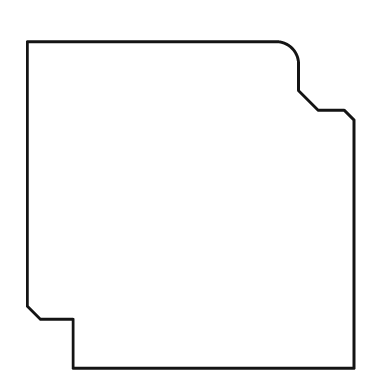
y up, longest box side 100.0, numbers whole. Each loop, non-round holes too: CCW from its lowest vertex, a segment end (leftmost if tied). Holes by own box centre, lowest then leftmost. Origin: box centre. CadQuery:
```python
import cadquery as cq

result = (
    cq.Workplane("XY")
    .moveTo(-36.0, -50.0)
    .lineTo(50.0, -50.0)
    .lineTo(50.0, 26.0)
    .lineTo(47.0, 29.0)
    .lineTo(39.0, 29.0)
    .lineTo(33.0, 35.0)
    .lineTo(33.0, 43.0)
    .threePointArc((31.0, 48.0), (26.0, 50.0))
    .lineTo(-50.0, 50.0)
    .lineTo(-50.0, -31.0)
    .lineTo(-46.0, -35.0)
    .lineTo(-36.0, -35.0)
    .close()
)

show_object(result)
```